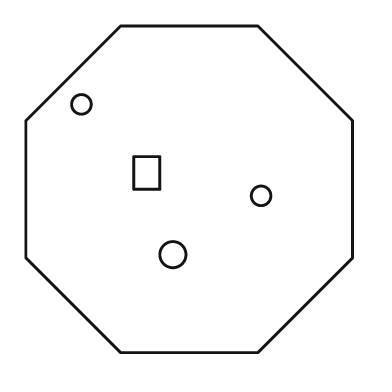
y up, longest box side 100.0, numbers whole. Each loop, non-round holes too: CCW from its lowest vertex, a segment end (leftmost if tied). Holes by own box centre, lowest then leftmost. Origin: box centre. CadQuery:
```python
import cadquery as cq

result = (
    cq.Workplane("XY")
    .moveTo(-21.0, -50.0)
    .lineTo(21.0, -50.0)
    .lineTo(50.0, -21.0)
    .lineTo(50.0, 21.0)
    .lineTo(21.0, 50.0)
    .lineTo(-21.0, 50.0)
    .lineTo(-50.0, 21.0)
    .lineTo(-50.0, -21.0)
    .close()
    .moveTo(-5.0, -20.0)
    .circle(4.0)
    .moveTo(22.0, -2.0)
    .circle(3.0)
    .moveTo(-17.0, 0.0)
    .lineTo(-9.0, 0.0)
    .lineTo(-9.0, 10.0)
    .lineTo(-17.0, 10.0)
    .close()
    .moveTo(-33.0, 26.0)
    .circle(3.0)
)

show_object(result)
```